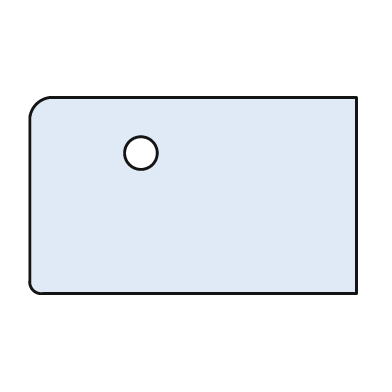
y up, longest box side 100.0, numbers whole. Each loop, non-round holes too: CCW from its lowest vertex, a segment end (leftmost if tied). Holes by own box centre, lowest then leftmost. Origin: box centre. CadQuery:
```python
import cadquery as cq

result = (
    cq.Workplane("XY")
    .moveTo(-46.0, -30.0)
    .lineTo(50.0, -30.0)
    .lineTo(50.0, 30.0)
    .lineTo(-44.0, 30.0)
    .threePointArc((-48.0, 28.0), (-50.0, 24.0))
    .lineTo(-50.0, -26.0)
    .threePointArc((-49.0, -29.0), (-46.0, -30.0))
    .close()
    .moveTo(-16.0, 13.0)
    .circle(5.0)
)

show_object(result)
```